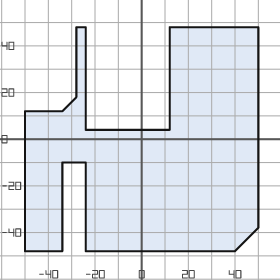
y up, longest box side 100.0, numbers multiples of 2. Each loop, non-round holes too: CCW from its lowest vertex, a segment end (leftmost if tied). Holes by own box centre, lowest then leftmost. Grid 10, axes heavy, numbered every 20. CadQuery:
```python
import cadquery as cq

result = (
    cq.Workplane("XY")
    .moveTo(-50.0, -48.0)
    .lineTo(-34.0, -48.0)
    .lineTo(-34.0, -10.0)
    .lineTo(-24.0, -10.0)
    .lineTo(-24.0, -48.0)
    .lineTo(40.0, -48.0)
    .lineTo(50.0, -38.0)
    .lineTo(50.0, 48.0)
    .lineTo(12.0, 48.0)
    .lineTo(12.0, 4.0)
    .lineTo(-24.0, 4.0)
    .lineTo(-24.0, 48.0)
    .lineTo(-28.0, 48.0)
    .lineTo(-28.0, 18.0)
    .lineTo(-34.0, 12.0)
    .lineTo(-50.0, 12.0)
    .close()
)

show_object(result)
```